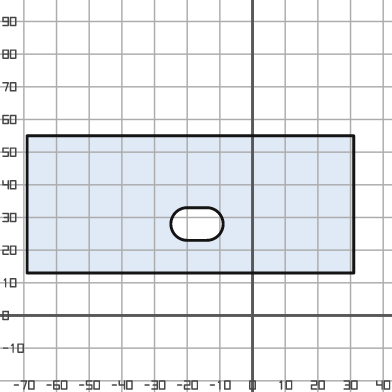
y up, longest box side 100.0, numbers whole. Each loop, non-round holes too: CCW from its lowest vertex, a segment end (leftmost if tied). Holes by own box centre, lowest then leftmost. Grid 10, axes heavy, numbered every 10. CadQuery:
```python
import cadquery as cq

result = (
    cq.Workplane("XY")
    .moveTo(-69.0, 13.0)
    .lineTo(31.0, 13.0)
    .lineTo(31.0, 55.0)
    .lineTo(-69.0, 55.0)
    .close()
    .moveTo(-20.0, 23.0)
    .lineTo(-14.0, 23.0)
    .threePointArc((-9.0, 28.0), (-14.0, 33.0))
    .lineTo(-20.0, 33.0)
    .threePointArc((-25.0, 28.0), (-20.0, 23.0))
    .close()
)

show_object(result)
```